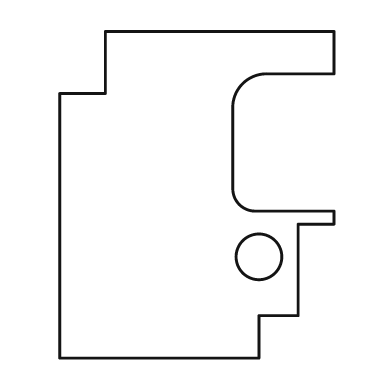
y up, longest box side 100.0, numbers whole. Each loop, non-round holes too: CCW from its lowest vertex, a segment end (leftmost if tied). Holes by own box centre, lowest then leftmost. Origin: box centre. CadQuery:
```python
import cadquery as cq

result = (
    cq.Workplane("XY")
    .moveTo(-42.0, -50.0)
    .lineTo(19.0, -50.0)
    .lineTo(19.0, -37.0)
    .lineTo(31.0, -37.0)
    .lineTo(31.0, -9.0)
    .lineTo(42.0, -9.0)
    .lineTo(42.0, -5.0)
    .lineTo(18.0, -5.0)
    .threePointArc((13.0, -3.0), (11.0, 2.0))
    .lineTo(11.0, 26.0)
    .threePointArc((14.0, 34.0), (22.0, 37.0))
    .lineTo(42.0, 37.0)
    .lineTo(42.0, 50.0)
    .lineTo(-28.0, 50.0)
    .lineTo(-28.0, 31.0)
    .lineTo(-42.0, 31.0)
    .close()
    .moveTo(19.0, -19.0)
    .circle(7.0)
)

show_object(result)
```